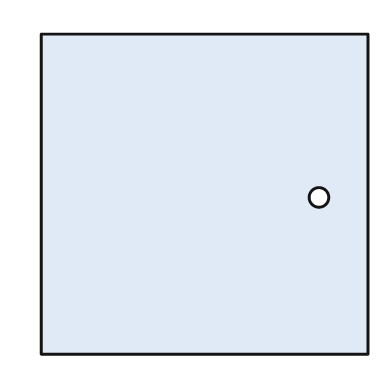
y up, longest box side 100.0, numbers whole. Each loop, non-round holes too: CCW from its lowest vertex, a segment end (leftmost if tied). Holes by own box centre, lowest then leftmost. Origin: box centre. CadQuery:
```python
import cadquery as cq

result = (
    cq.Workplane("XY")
    .moveTo(-50.0, -49.0)
    .lineTo(50.0, -49.0)
    .lineTo(50.0, 49.0)
    .lineTo(-50.0, 49.0)
    .close()
    .moveTo(35.0, -1.0)
    .circle(3.0)
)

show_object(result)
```